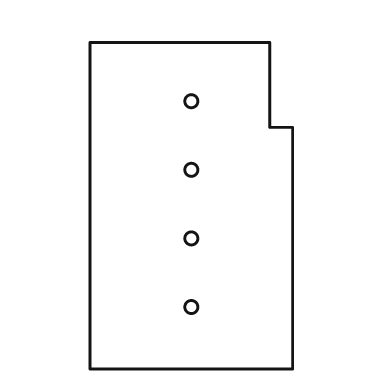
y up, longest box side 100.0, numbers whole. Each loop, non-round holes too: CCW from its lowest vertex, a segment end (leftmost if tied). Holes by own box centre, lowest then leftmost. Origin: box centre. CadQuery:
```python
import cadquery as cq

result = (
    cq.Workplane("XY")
    .moveTo(-31.0, -50.0)
    .lineTo(31.0, -50.0)
    .lineTo(31.0, 24.0)
    .lineTo(24.0, 24.0)
    .lineTo(24.0, 50.0)
    .lineTo(-31.0, 50.0)
    .close()
    .moveTo(0.0, -31.0)
    .circle(2.0)
    .moveTo(0.0, -10.0)
    .circle(2.0)
    .moveTo(0.0, 11.0)
    .circle(2.0)
    .moveTo(0.0, 32.0)
    .circle(2.0)
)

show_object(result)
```